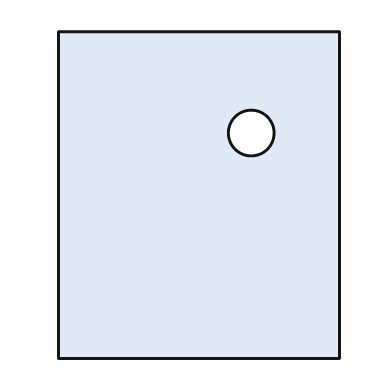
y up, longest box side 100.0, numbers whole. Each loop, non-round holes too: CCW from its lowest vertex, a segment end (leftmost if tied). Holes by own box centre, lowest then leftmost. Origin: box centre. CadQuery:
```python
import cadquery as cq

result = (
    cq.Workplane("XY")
    .moveTo(-43.0, -50.0)
    .lineTo(43.0, -50.0)
    .lineTo(43.0, 50.0)
    .lineTo(-43.0, 50.0)
    .close()
    .moveTo(16.0, 19.0)
    .circle(7.0)
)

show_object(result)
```